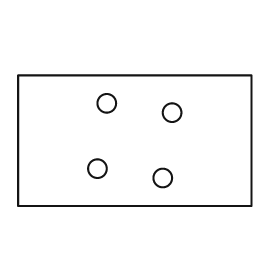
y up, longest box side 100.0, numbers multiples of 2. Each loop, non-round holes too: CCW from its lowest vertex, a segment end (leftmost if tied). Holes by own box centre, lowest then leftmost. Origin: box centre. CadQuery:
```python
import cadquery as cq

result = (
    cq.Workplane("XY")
    .moveTo(-50.0, -28.0)
    .lineTo(50.0, -28.0)
    .lineTo(50.0, 28.0)
    .lineTo(-50.0, 28.0)
    .close()
    .moveTo(12.0, -16.0)
    .circle(4.0)
    .moveTo(-16.0, -12.0)
    .circle(4.0)
    .moveTo(16.0, 12.0)
    .circle(4.0)
    .moveTo(-12.0, 16.0)
    .circle(4.0)
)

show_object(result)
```